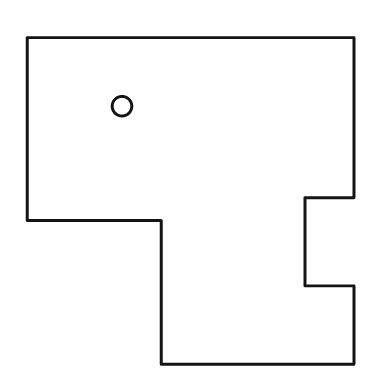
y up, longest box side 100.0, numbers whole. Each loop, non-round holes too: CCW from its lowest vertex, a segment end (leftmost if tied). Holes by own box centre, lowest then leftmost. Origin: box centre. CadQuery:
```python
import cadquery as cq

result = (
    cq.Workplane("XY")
    .moveTo(-9.0, -50.0)
    .lineTo(50.0, -50.0)
    .lineTo(50.0, -26.0)
    .lineTo(35.0, -26.0)
    .lineTo(35.0, 1.0)
    .lineTo(50.0, 1.0)
    .lineTo(50.0, 50.0)
    .lineTo(-50.0, 50.0)
    .lineTo(-50.0, -6.0)
    .lineTo(-9.0, -6.0)
    .close()
    .moveTo(-21.0, 29.0)
    .circle(3.0)
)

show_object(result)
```